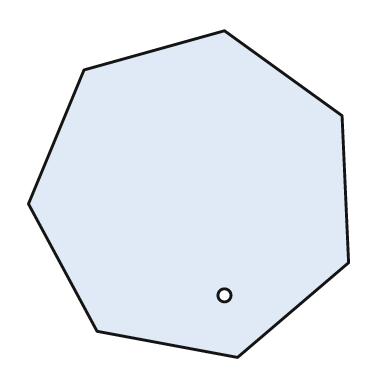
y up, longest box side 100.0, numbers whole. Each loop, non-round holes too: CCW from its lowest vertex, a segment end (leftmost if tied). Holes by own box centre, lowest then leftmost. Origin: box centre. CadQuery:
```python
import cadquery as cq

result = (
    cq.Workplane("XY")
    .moveTo(15.0, -50.0)
    .lineTo(49.0, -21.0)
    .lineTo(47.0, 24.0)
    .lineTo(11.0, 50.0)
    .lineTo(-32.0, 38.0)
    .lineTo(-49.0, -3.0)
    .lineTo(-28.0, -42.0)
    .close()
    .moveTo(11.0, -31.0)
    .circle(2.0)
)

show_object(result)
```